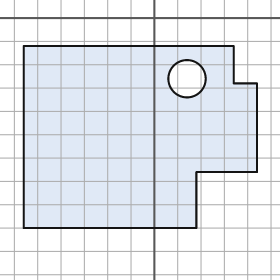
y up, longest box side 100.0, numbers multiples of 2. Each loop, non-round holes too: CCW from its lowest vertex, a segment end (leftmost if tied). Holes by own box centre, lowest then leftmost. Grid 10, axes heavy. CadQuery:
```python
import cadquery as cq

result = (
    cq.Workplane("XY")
    .moveTo(-56.0, -90.0)
    .lineTo(18.0, -90.0)
    .lineTo(18.0, -66.0)
    .lineTo(44.0, -66.0)
    .lineTo(44.0, -28.0)
    .lineTo(34.0, -28.0)
    .lineTo(34.0, -12.0)
    .lineTo(-56.0, -12.0)
    .close()
    .moveTo(14.0, -26.0)
    .circle(8.0)
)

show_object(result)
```